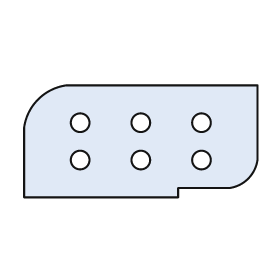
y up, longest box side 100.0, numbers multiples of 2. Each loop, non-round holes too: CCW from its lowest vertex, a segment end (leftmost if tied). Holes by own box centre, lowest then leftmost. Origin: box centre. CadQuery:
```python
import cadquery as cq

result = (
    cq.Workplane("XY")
    .moveTo(-50.0, -24.0)
    .lineTo(16.0, -24.0)
    .lineTo(16.0, -20.0)
    .lineTo(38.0, -20.0)
    .threePointArc((46.0, -16.0), (50.0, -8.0))
    .lineTo(50.0, 24.0)
    .lineTo(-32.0, 24.0)
    .threePointArc((-44.0, 18.0), (-50.0, 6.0))
    .close()
    .moveTo(-26.0, -8.0)
    .circle(4.0)
    .moveTo(0.0, -8.0)
    .circle(4.0)
    .moveTo(26.0, -8.0)
    .circle(4.0)
    .moveTo(-26.0, 8.0)
    .circle(4.0)
    .moveTo(0.0, 8.0)
    .circle(4.0)
    .moveTo(26.0, 8.0)
    .circle(4.0)
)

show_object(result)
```